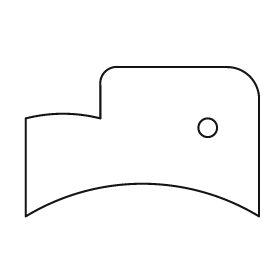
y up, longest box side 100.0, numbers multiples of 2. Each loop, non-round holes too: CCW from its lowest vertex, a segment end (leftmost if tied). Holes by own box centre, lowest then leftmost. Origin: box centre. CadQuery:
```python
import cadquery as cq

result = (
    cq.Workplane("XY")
    .moveTo(-50.0, -32.0)
    .threePointArc((0.0, -18.0), (50.0, -32.0))
    .lineTo(50.0, 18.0)
    .threePointArc((46.0, 28.0), (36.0, 32.0))
    .lineTo(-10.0, 32.0)
    .threePointArc((-16.0, 30.0), (-18.0, 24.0))
    .lineTo(-18.0, 10.0)
    .threePointArc((-34.0, 12.0), (-50.0, 10.0))
    .close()
    .moveTo(28.0, 6.0)
    .circle(4.0)
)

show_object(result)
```